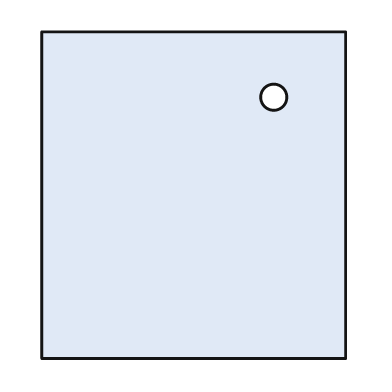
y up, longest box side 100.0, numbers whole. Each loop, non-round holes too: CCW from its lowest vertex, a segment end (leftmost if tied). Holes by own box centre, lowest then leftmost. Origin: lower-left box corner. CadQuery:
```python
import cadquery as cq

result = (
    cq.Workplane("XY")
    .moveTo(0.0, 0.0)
    .lineTo(93.0, 0.0)
    .lineTo(93.0, 100.0)
    .lineTo(0.0, 100.0)
    .close()
    .moveTo(71.0, 80.0)
    .circle(4.0)
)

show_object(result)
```